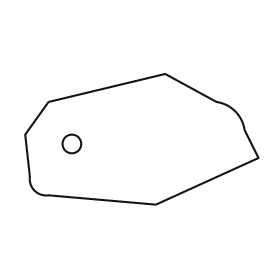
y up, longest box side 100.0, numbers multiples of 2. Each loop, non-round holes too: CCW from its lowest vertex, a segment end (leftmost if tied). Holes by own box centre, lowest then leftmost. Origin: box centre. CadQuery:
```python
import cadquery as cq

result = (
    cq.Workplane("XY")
    .moveTo(6.0, -28.0)
    .lineTo(50.0, -8.0)
    .lineTo(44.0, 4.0)
    .threePointArc((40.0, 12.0), (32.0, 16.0))
    .lineTo(10.0, 28.0)
    .lineTo(-40.0, 16.0)
    .lineTo(-50.0, 2.0)
    .lineTo(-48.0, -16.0)
    .threePointArc((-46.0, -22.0), (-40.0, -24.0))
    .close()
    .moveTo(-30.0, -2.0)
    .circle(4.0)
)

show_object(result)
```